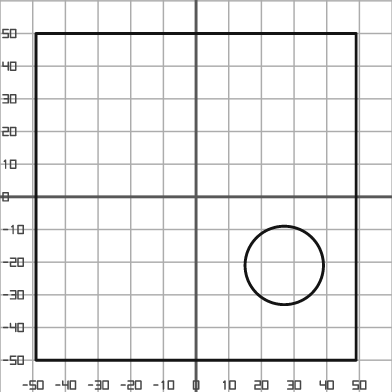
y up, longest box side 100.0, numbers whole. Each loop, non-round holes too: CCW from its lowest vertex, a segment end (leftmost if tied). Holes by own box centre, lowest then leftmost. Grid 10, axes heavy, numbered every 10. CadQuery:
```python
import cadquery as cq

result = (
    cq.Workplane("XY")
    .moveTo(-49.0, -50.0)
    .lineTo(49.0, -50.0)
    .lineTo(49.0, 50.0)
    .lineTo(-49.0, 50.0)
    .close()
    .moveTo(27.0, -21.0)
    .circle(12.0)
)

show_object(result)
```